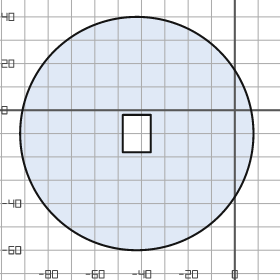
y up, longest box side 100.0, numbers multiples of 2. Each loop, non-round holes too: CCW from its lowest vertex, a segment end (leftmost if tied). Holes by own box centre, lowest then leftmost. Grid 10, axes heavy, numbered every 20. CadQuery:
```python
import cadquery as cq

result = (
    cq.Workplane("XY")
    .moveTo(-42.0, -10.0)
    .circle(50.0)
    .moveTo(-48.0, -18.0)
    .lineTo(-36.0, -18.0)
    .lineTo(-36.0, -2.0)
    .lineTo(-48.0, -2.0)
    .close()
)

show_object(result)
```